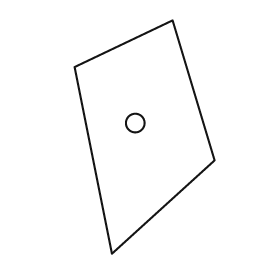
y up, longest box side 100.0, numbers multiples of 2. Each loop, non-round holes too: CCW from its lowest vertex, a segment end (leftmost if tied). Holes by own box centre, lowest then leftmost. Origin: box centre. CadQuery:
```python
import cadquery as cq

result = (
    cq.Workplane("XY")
    .moveTo(-14.0, -50.0)
    .lineTo(30.0, -10.0)
    .lineTo(12.0, 50.0)
    .lineTo(-30.0, 30.0)
    .close()
    .moveTo(-4.0, 6.0)
    .circle(4.0)
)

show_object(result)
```